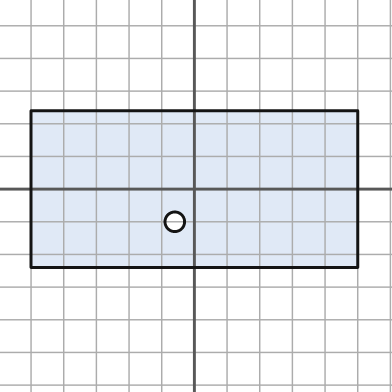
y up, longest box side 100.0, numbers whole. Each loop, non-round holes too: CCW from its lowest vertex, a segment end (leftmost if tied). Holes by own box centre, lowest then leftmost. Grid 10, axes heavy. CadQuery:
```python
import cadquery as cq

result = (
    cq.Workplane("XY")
    .moveTo(-50.0, -24.0)
    .lineTo(50.0, -24.0)
    .lineTo(50.0, 24.0)
    .lineTo(-50.0, 24.0)
    .close()
    .moveTo(-6.0, -10.0)
    .circle(3.0)
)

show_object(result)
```